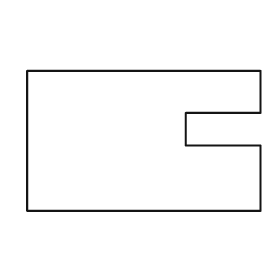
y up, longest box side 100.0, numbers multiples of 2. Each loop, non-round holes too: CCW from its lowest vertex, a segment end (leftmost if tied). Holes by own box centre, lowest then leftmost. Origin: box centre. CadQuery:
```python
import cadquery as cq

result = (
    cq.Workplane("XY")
    .moveTo(-50.0, -30.0)
    .lineTo(50.0, -30.0)
    .lineTo(50.0, -2.0)
    .lineTo(18.0, -2.0)
    .lineTo(18.0, 12.0)
    .lineTo(50.0, 12.0)
    .lineTo(50.0, 30.0)
    .lineTo(-50.0, 30.0)
    .close()
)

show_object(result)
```